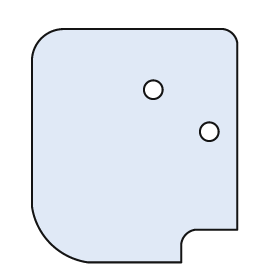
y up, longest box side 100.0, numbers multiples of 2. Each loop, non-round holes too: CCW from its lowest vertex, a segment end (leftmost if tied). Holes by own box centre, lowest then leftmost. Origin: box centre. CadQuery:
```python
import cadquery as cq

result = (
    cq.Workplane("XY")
    .moveTo(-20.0, -50.0)
    .lineTo(20.0, -50.0)
    .lineTo(20.0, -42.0)
    .threePointArc((22.0, -38.0), (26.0, -36.0))
    .lineTo(44.0, -36.0)
    .lineTo(44.0, 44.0)
    .threePointArc((42.0, 48.0), (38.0, 50.0))
    .lineTo(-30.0, 50.0)
    .threePointArc((-40.0, 46.0), (-44.0, 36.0))
    .lineTo(-44.0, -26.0)
    .threePointArc((-36.0, -42.0), (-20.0, -50.0))
    .close()
    .moveTo(32.0, 6.0)
    .circle(4.0)
    .moveTo(8.0, 24.0)
    .circle(4.0)
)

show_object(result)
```